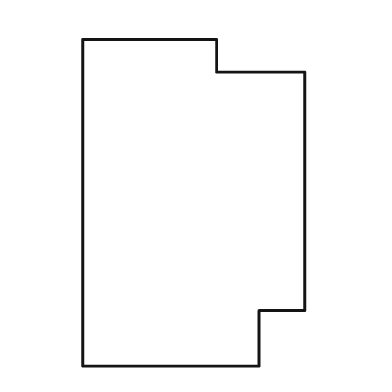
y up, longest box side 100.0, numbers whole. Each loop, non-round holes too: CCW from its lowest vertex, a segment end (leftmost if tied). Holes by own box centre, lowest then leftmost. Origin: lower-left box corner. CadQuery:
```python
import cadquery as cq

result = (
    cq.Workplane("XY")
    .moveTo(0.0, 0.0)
    .lineTo(54.0, 0.0)
    .lineTo(54.0, 17.0)
    .lineTo(68.0, 17.0)
    .lineTo(68.0, 90.0)
    .lineTo(41.0, 90.0)
    .lineTo(41.0, 100.0)
    .lineTo(0.0, 100.0)
    .close()
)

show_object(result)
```